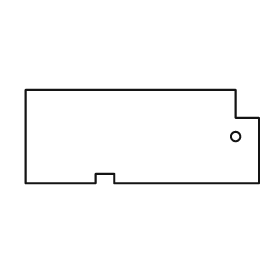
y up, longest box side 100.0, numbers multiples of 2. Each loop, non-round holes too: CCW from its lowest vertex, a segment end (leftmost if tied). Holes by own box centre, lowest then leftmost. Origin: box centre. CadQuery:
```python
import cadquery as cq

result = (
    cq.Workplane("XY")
    .moveTo(-50.0, -20.0)
    .lineTo(-20.0, -20.0)
    .lineTo(-20.0, -16.0)
    .lineTo(-12.0, -16.0)
    .lineTo(-12.0, -20.0)
    .lineTo(50.0, -20.0)
    .lineTo(50.0, 8.0)
    .lineTo(40.0, 8.0)
    .lineTo(40.0, 20.0)
    .lineTo(-50.0, 20.0)
    .close()
    .moveTo(40.0, 0.0)
    .circle(2.0)
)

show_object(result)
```